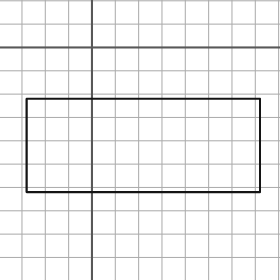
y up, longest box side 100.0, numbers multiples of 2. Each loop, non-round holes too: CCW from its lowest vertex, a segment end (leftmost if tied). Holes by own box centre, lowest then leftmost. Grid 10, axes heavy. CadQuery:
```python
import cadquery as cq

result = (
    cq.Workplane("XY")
    .moveTo(-28.0, -62.0)
    .lineTo(72.0, -62.0)
    .lineTo(72.0, -22.0)
    .lineTo(-28.0, -22.0)
    .close()
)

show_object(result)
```